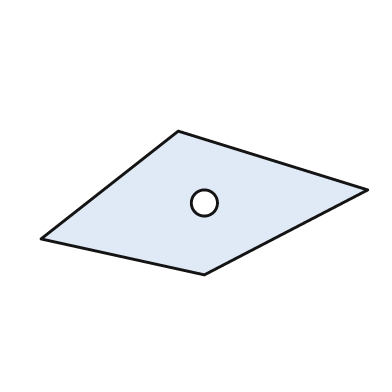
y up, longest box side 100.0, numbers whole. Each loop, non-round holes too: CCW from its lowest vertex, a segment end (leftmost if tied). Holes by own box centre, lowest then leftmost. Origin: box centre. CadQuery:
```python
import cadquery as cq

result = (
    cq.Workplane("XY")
    .moveTo(0.0, -22.0)
    .lineTo(50.0, 4.0)
    .lineTo(-8.0, 22.0)
    .lineTo(-50.0, -11.0)
    .close()
    .moveTo(0.0, 0.0)
    .circle(4.0)
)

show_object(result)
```